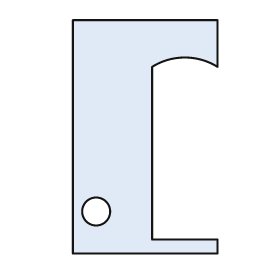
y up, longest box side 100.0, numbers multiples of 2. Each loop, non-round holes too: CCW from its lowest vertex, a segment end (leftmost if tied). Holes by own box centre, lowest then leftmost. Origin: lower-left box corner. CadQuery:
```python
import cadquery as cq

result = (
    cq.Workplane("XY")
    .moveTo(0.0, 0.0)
    .lineTo(62.0, 0.0)
    .lineTo(62.0, 6.0)
    .lineTo(34.0, 6.0)
    .lineTo(34.0, 80.0)
    .threePointArc((48.0, 84.0), (62.0, 80.0))
    .lineTo(62.0, 100.0)
    .lineTo(0.0, 100.0)
    .close()
    .moveTo(10.0, 18.0)
    .circle(6.0)
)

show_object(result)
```